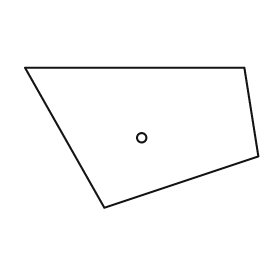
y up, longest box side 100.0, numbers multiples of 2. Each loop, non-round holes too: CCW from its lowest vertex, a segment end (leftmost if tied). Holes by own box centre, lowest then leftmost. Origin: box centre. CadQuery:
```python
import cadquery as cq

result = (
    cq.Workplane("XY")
    .moveTo(-16.0, -30.0)
    .lineTo(50.0, -8.0)
    .lineTo(44.0, 30.0)
    .lineTo(-50.0, 30.0)
    .close()
    .moveTo(0.0, 0.0)
    .circle(2.0)
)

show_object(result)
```